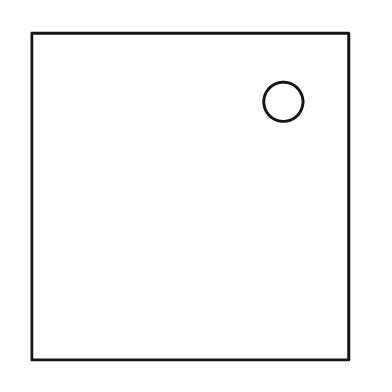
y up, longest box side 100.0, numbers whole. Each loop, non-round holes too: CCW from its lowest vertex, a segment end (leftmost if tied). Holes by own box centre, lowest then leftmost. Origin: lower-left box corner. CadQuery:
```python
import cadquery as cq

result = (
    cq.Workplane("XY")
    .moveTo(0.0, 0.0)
    .lineTo(97.0, 0.0)
    .lineTo(97.0, 100.0)
    .lineTo(0.0, 100.0)
    .close()
    .moveTo(77.0, 79.0)
    .circle(6.0)
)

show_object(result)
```